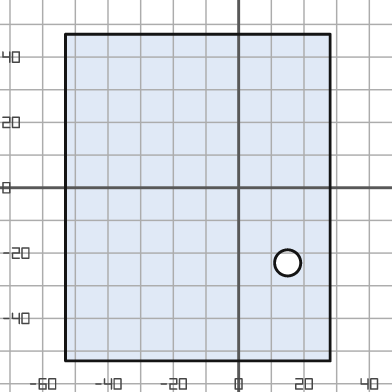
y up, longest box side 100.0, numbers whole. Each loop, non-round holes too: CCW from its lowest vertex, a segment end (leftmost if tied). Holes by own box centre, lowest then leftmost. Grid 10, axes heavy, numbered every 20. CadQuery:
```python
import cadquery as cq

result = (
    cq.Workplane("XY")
    .moveTo(-53.0, -53.0)
    .lineTo(28.0, -53.0)
    .lineTo(28.0, 47.0)
    .lineTo(-53.0, 47.0)
    .close()
    .moveTo(15.0, -23.0)
    .circle(4.0)
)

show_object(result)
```